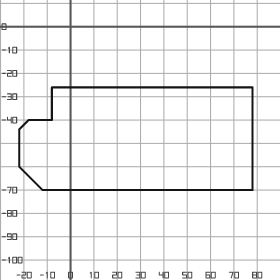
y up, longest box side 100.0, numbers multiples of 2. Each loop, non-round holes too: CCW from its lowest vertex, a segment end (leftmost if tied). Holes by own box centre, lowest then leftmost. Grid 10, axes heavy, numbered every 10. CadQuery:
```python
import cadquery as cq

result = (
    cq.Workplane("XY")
    .moveTo(-12.0, -70.0)
    .lineTo(78.0, -70.0)
    .lineTo(78.0, -26.0)
    .lineTo(-8.0, -26.0)
    .lineTo(-8.0, -40.0)
    .lineTo(-18.0, -40.0)
    .lineTo(-22.0, -44.0)
    .lineTo(-22.0, -60.0)
    .close()
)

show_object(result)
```